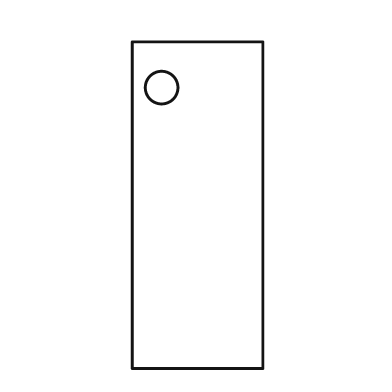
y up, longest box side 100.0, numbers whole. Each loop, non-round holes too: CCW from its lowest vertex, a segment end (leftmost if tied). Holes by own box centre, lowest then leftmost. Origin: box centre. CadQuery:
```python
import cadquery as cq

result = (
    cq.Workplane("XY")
    .moveTo(-20.0, -50.0)
    .lineTo(20.0, -50.0)
    .lineTo(20.0, 50.0)
    .lineTo(-20.0, 50.0)
    .close()
    .moveTo(-11.0, 36.0)
    .circle(5.0)
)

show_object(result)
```